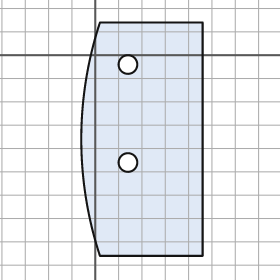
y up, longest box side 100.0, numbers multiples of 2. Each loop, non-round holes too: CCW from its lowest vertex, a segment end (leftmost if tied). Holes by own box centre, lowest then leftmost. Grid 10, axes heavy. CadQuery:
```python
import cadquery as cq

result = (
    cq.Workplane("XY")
    .moveTo(2.0, -86.0)
    .lineTo(46.0, -86.0)
    .lineTo(46.0, 14.0)
    .lineTo(2.0, 14.0)
    .threePointArc((-6.0, -36.0), (2.0, -86.0))
    .close()
    .moveTo(14.0, -46.0)
    .circle(4.0)
    .moveTo(14.0, -4.0)
    .circle(4.0)
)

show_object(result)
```